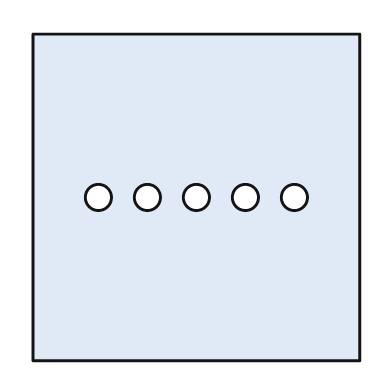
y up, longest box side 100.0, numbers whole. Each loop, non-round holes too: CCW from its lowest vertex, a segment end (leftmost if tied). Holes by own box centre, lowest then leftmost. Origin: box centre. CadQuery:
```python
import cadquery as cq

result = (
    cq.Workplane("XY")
    .moveTo(-50.0, -50.0)
    .lineTo(50.0, -50.0)
    .lineTo(50.0, 50.0)
    .lineTo(-50.0, 50.0)
    .close()
    .moveTo(-30.0, 0.0)
    .circle(4.0)
    .moveTo(-15.0, 0.0)
    .circle(4.0)
    .moveTo(0.0, 0.0)
    .circle(4.0)
    .moveTo(15.0, 0.0)
    .circle(4.0)
    .moveTo(30.0, 0.0)
    .circle(4.0)
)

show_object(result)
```